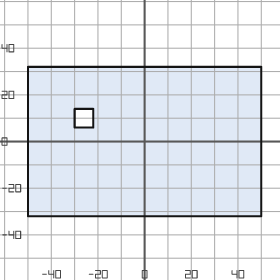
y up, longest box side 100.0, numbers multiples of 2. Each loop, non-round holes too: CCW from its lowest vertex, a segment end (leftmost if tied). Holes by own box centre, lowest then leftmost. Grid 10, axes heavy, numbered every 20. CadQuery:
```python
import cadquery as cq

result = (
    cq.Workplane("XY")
    .moveTo(-50.0, -32.0)
    .lineTo(50.0, -32.0)
    .lineTo(50.0, 32.0)
    .lineTo(-50.0, 32.0)
    .close()
    .moveTo(-30.0, 6.0)
    .lineTo(-22.0, 6.0)
    .lineTo(-22.0, 14.0)
    .lineTo(-30.0, 14.0)
    .close()
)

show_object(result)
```